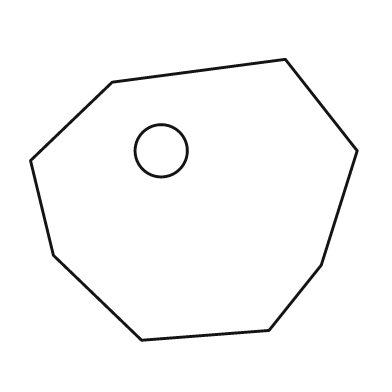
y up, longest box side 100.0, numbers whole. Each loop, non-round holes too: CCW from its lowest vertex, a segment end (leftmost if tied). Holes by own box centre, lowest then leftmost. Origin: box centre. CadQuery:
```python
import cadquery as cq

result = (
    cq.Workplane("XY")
    .moveTo(-16.0, -43.0)
    .lineTo(23.0, -40.0)
    .lineTo(39.0, -20.0)
    .lineTo(50.0, 15.0)
    .lineTo(28.0, 43.0)
    .lineTo(-25.0, 36.0)
    .lineTo(-50.0, 12.0)
    .lineTo(-43.0, -17.0)
    .close()
    .moveTo(-10.0, 15.0)
    .circle(8.0)
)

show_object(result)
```